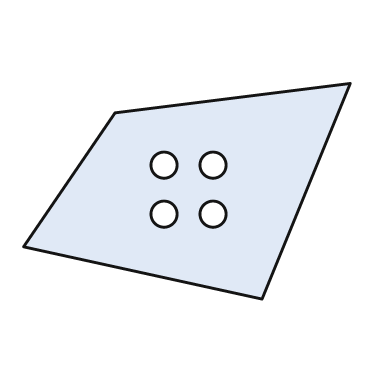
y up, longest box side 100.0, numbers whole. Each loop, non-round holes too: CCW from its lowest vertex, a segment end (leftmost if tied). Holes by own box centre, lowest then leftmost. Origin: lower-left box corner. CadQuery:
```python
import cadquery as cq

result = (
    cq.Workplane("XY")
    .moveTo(73.0, 0.0)
    .lineTo(100.0, 66.0)
    .lineTo(28.0, 57.0)
    .lineTo(0.0, 16.0)
    .close()
    .moveTo(43.0, 26.0)
    .circle(4.0)
    .moveTo(58.0, 26.0)
    .circle(4.0)
    .moveTo(43.0, 41.0)
    .circle(4.0)
    .moveTo(58.0, 41.0)
    .circle(4.0)
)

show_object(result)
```